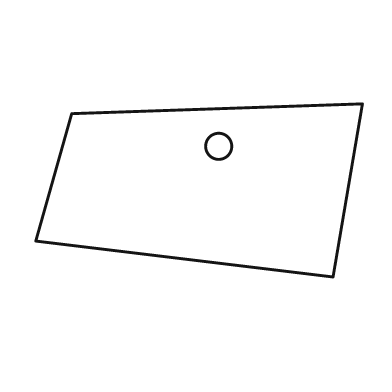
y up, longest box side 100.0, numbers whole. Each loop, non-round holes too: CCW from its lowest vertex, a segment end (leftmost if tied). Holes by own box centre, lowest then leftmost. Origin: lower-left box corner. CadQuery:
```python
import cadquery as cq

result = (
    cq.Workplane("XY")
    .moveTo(91.0, 0.0)
    .lineTo(100.0, 53.0)
    .lineTo(11.0, 50.0)
    .lineTo(0.0, 11.0)
    .close()
    .moveTo(56.0, 40.0)
    .circle(4.0)
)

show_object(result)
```